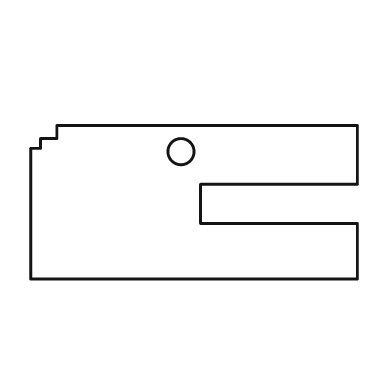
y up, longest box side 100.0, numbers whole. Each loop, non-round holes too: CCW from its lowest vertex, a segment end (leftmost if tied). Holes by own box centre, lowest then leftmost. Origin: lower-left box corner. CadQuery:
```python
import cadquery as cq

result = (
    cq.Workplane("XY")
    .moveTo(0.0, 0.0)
    .lineTo(100.0, 0.0)
    .lineTo(100.0, 17.0)
    .lineTo(52.0, 17.0)
    .lineTo(52.0, 29.0)
    .lineTo(100.0, 29.0)
    .lineTo(100.0, 47.0)
    .lineTo(8.0, 47.0)
    .lineTo(8.0, 43.0)
    .lineTo(3.0, 43.0)
    .lineTo(3.0, 40.0)
    .lineTo(0.0, 40.0)
    .close()
    .moveTo(46.0, 39.0)
    .circle(4.0)
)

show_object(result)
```